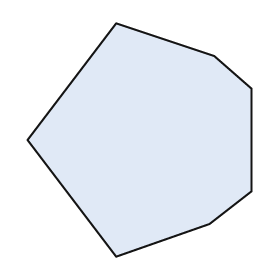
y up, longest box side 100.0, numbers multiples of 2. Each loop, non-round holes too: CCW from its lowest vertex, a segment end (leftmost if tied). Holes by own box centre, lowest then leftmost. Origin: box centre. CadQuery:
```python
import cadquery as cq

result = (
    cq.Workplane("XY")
    .moveTo(-10.0, -50.0)
    .lineTo(30.0, -36.0)
    .lineTo(48.0, -22.0)
    .lineTo(48.0, 22.0)
    .lineTo(32.0, 36.0)
    .lineTo(-10.0, 50.0)
    .lineTo(-48.0, 0.0)
    .close()
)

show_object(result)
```